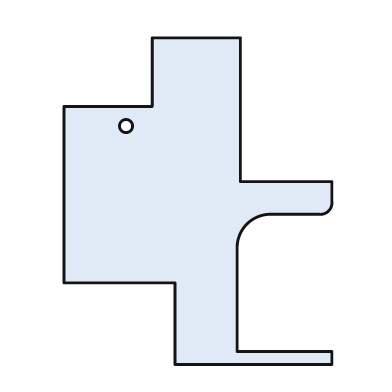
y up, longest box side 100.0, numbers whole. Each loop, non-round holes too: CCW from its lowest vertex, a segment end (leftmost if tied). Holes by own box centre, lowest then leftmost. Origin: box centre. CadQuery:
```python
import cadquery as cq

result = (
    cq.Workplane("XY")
    .moveTo(-7.0, -50.0)
    .lineTo(41.0, -50.0)
    .lineTo(41.0, -46.0)
    .lineTo(12.0, -46.0)
    .lineTo(12.0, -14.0)
    .threePointArc((15.0, -7.0), (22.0, -4.0))
    .lineTo(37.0, -4.0)
    .threePointArc((40.0, -3.0), (41.0, 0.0))
    .lineTo(41.0, 6.0)
    .lineTo(13.0, 6.0)
    .lineTo(13.0, 50.0)
    .lineTo(-14.0, 50.0)
    .lineTo(-14.0, 29.0)
    .lineTo(-41.0, 29.0)
    .lineTo(-41.0, -25.0)
    .lineTo(-7.0, -25.0)
    .close()
    .moveTo(-22.0, 23.0)
    .circle(2.0)
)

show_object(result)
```